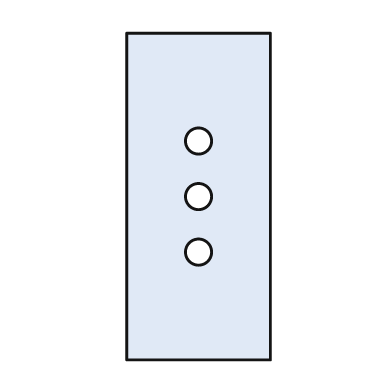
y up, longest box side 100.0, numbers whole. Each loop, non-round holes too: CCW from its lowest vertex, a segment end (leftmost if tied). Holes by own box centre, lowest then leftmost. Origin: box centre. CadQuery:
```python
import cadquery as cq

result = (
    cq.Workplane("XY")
    .moveTo(-22.0, -50.0)
    .lineTo(22.0, -50.0)
    .lineTo(22.0, 50.0)
    .lineTo(-22.0, 50.0)
    .close()
    .moveTo(0.0, -17.0)
    .circle(4.0)
    .moveTo(0.0, 0.0)
    .circle(4.0)
    .moveTo(0.0, 17.0)
    .circle(4.0)
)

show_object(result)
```